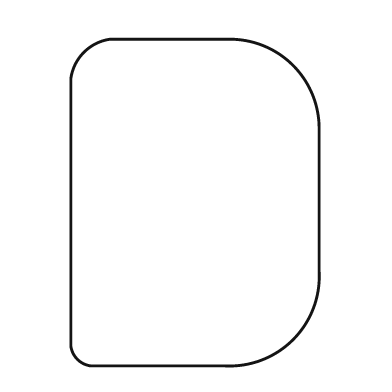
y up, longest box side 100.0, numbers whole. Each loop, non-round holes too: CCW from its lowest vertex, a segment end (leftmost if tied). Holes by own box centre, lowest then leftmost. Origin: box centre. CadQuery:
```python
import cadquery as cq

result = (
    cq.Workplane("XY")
    .moveTo(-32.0, -50.0)
    .lineTo(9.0, -50.0)
    .threePointArc((30.0, -42.0), (38.0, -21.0))
    .lineTo(38.0, 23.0)
    .threePointArc((30.0, 42.0), (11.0, 50.0))
    .lineTo(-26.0, 50.0)
    .threePointArc((-34.0, 46.0), (-38.0, 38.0))
    .lineTo(-38.0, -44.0)
    .threePointArc((-36.0, -48.0), (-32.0, -50.0))
    .close()
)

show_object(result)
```